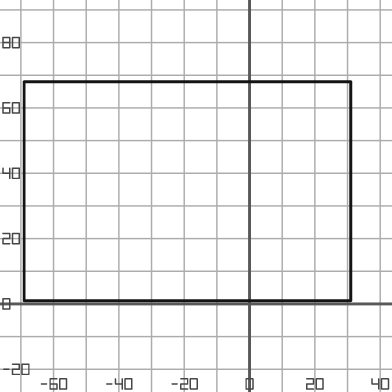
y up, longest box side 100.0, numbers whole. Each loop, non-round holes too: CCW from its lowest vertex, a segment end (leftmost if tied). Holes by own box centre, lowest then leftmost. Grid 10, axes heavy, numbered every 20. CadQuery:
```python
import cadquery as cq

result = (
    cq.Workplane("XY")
    .moveTo(-69.0, 1.0)
    .lineTo(31.0, 1.0)
    .lineTo(31.0, 68.0)
    .lineTo(-69.0, 68.0)
    .close()
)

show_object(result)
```